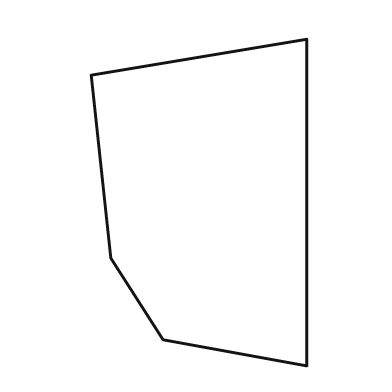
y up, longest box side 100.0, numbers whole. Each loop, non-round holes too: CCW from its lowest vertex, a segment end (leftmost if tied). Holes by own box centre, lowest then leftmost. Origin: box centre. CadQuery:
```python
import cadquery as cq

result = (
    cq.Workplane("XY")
    .moveTo(33.0, -50.0)
    .lineTo(33.0, 50.0)
    .lineTo(-33.0, 39.0)
    .lineTo(-27.0, -17.0)
    .lineTo(-11.0, -42.0)
    .close()
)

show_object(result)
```